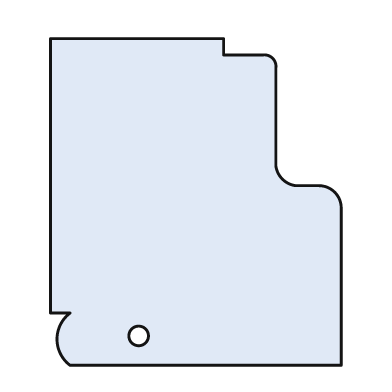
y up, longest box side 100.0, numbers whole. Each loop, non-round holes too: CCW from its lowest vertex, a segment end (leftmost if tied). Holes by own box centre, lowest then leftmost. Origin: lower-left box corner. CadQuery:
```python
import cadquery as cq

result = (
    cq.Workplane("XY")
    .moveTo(6.0, 0.0)
    .lineTo(89.0, 0.0)
    .lineTo(89.0, 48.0)
    .threePointArc((87.0, 53.0), (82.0, 55.0))
    .lineTo(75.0, 55.0)
    .threePointArc((71.0, 57.0), (69.0, 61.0))
    .lineTo(69.0, 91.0)
    .threePointArc((68.0, 94.0), (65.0, 95.0))
    .lineTo(53.0, 95.0)
    .lineTo(53.0, 100.0)
    .lineTo(0.0, 100.0)
    .lineTo(0.0, 16.0)
    .lineTo(6.0, 16.0)
    .threePointArc((2.0, 8.0), (6.0, 0.0))
    .close()
    .moveTo(27.0, 9.0)
    .circle(3.0)
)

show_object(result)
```